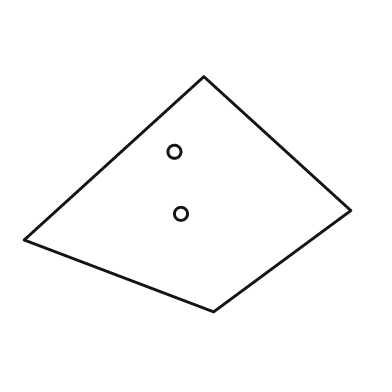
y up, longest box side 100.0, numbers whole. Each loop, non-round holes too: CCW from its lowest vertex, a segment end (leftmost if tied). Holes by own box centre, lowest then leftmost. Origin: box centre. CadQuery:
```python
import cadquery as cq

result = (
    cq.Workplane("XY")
    .moveTo(8.0, -36.0)
    .lineTo(50.0, -5.0)
    .lineTo(5.0, 36.0)
    .lineTo(-50.0, -14.0)
    .close()
    .moveTo(-2.0, -6.0)
    .circle(2.0)
    .moveTo(-4.0, 13.0)
    .circle(2.0)
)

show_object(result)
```